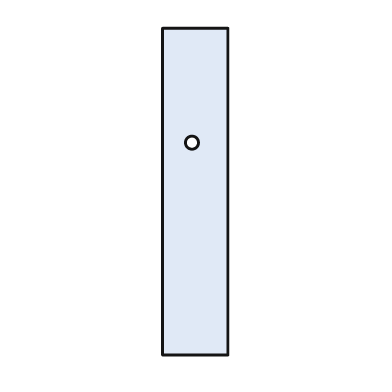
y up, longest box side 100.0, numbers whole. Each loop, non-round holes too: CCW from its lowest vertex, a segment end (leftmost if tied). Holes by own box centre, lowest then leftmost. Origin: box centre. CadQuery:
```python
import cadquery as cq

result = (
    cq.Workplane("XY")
    .moveTo(-10.0, -50.0)
    .lineTo(10.0, -50.0)
    .lineTo(10.0, 50.0)
    .lineTo(-10.0, 50.0)
    .close()
    .moveTo(-1.0, 15.0)
    .circle(2.0)
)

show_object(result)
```